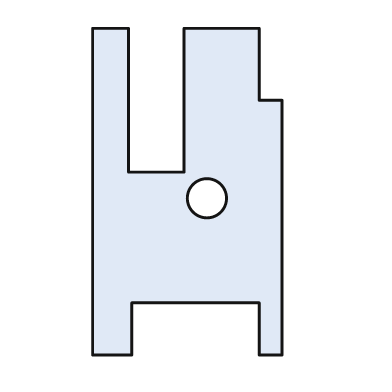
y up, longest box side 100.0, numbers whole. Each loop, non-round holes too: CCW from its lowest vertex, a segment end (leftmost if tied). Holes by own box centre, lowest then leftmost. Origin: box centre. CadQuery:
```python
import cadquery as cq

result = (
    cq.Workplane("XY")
    .moveTo(-29.0, -50.0)
    .lineTo(-17.0, -50.0)
    .lineTo(-17.0, -34.0)
    .lineTo(22.0, -34.0)
    .lineTo(22.0, -50.0)
    .lineTo(29.0, -50.0)
    .lineTo(29.0, 28.0)
    .lineTo(22.0, 28.0)
    .lineTo(22.0, 50.0)
    .lineTo(-1.0, 50.0)
    .lineTo(-1.0, 6.0)
    .lineTo(-18.0, 6.0)
    .lineTo(-18.0, 50.0)
    .lineTo(-29.0, 50.0)
    .close()
    .moveTo(6.0, -2.0)
    .circle(6.0)
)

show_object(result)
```